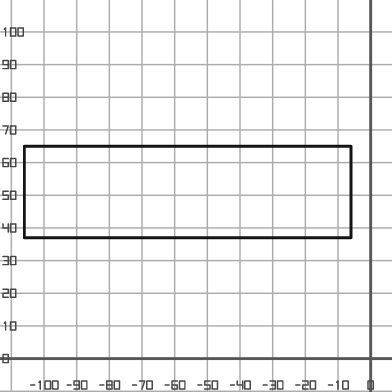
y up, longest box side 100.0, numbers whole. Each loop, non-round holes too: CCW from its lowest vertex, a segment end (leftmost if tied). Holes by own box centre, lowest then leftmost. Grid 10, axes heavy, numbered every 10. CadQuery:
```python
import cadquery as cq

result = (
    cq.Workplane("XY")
    .moveTo(-106.0, 37.0)
    .lineTo(-6.0, 37.0)
    .lineTo(-6.0, 65.0)
    .lineTo(-106.0, 65.0)
    .close()
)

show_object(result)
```